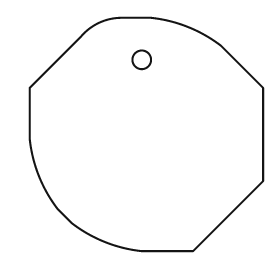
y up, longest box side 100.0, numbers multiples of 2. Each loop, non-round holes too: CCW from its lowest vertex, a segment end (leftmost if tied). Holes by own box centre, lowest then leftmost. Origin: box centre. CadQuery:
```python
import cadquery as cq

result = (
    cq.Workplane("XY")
    .moveTo(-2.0, -50.0)
    .lineTo(20.0, -50.0)
    .lineTo(50.0, -20.0)
    .lineTo(50.0, 20.0)
    .lineTo(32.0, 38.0)
    .threePointArc((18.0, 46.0), (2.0, 50.0))
    .lineTo(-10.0, 50.0)
    .threePointArc((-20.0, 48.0), (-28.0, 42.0))
    .lineTo(-50.0, 20.0)
    .lineTo(-50.0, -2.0)
    .threePointArc((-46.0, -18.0), (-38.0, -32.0))
    .lineTo(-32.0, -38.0)
    .threePointArc((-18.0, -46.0), (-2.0, -50.0))
    .close()
    .moveTo(-2.0, 32.0)
    .circle(4.0)
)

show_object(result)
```